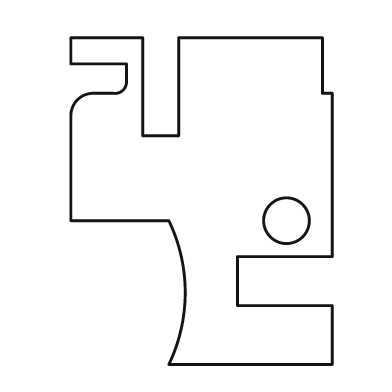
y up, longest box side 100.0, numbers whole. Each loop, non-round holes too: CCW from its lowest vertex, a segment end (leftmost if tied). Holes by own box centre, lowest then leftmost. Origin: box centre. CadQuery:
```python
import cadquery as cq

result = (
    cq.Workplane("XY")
    .moveTo(-10.0, -50.0)
    .lineTo(40.0, -50.0)
    .lineTo(40.0, -32.0)
    .lineTo(11.0, -32.0)
    .lineTo(11.0, -17.0)
    .lineTo(40.0, -17.0)
    .lineTo(40.0, 33.0)
    .lineTo(37.0, 33.0)
    .lineTo(37.0, 50.0)
    .lineTo(-7.0, 50.0)
    .lineTo(-7.0, 20.0)
    .lineTo(-18.0, 20.0)
    .lineTo(-18.0, 50.0)
    .lineTo(-40.0, 50.0)
    .lineTo(-40.0, 42.0)
    .lineTo(-23.0, 42.0)
    .lineTo(-23.0, 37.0)
    .threePointArc((-24.0, 34.0), (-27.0, 33.0))
    .lineTo(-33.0, 33.0)
    .threePointArc((-38.0, 31.0), (-40.0, 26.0))
    .lineTo(-40.0, -6.0)
    .lineTo(-10.0, -6.0)
    .threePointArc((-5.0, -28.0), (-10.0, -50.0))
    .close()
    .moveTo(26.0, -6.0)
    .circle(7.0)
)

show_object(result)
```